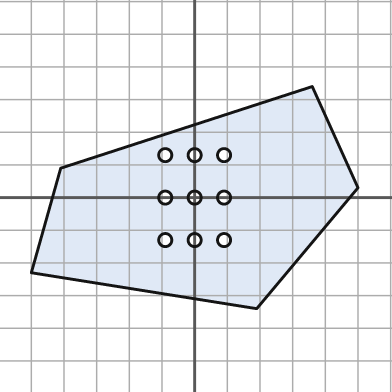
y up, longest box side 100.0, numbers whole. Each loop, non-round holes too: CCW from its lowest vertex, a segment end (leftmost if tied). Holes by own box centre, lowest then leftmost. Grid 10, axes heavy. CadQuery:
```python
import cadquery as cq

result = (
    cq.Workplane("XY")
    .moveTo(19.0, -34.0)
    .lineTo(50.0, 3.0)
    .lineTo(36.0, 34.0)
    .lineTo(-41.0, 9.0)
    .lineTo(-50.0, -23.0)
    .close()
    .moveTo(-9.0, -13.0)
    .circle(2.0)
    .moveTo(0.0, -13.0)
    .circle(2.0)
    .moveTo(9.0, -13.0)
    .circle(2.0)
    .moveTo(-9.0, 0.0)
    .circle(2.0)
    .moveTo(0.0, 0.0)
    .circle(2.0)
    .moveTo(9.0, 0.0)
    .circle(2.0)
    .moveTo(-9.0, 13.0)
    .circle(2.0)
    .moveTo(0.0, 13.0)
    .circle(2.0)
    .moveTo(9.0, 13.0)
    .circle(2.0)
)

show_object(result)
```